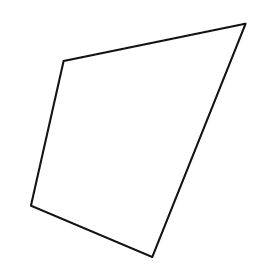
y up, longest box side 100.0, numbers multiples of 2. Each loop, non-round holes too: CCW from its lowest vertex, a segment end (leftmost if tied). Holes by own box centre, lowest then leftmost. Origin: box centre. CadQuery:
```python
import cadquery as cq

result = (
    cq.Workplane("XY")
    .moveTo(6.0, -50.0)
    .lineTo(46.0, 50.0)
    .lineTo(-32.0, 34.0)
    .lineTo(-46.0, -28.0)
    .close()
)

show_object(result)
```